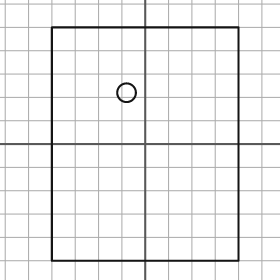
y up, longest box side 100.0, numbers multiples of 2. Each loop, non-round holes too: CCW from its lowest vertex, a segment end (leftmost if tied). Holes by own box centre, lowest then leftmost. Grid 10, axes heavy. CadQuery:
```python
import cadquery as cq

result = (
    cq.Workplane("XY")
    .moveTo(-40.0, -50.0)
    .lineTo(40.0, -50.0)
    .lineTo(40.0, 50.0)
    .lineTo(-40.0, 50.0)
    .close()
    .moveTo(-8.0, 22.0)
    .circle(4.0)
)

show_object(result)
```